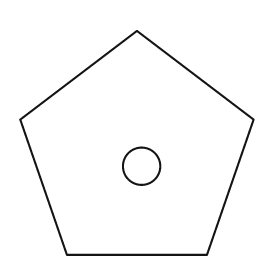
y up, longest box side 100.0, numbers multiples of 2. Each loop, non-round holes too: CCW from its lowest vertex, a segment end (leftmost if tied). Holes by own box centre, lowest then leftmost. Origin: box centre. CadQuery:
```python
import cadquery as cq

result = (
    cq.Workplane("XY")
    .moveTo(-30.0, -48.0)
    .lineTo(30.0, -48.0)
    .lineTo(50.0, 10.0)
    .lineTo(0.0, 48.0)
    .lineTo(-50.0, 10.0)
    .close()
    .moveTo(2.0, -10.0)
    .circle(8.0)
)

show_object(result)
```